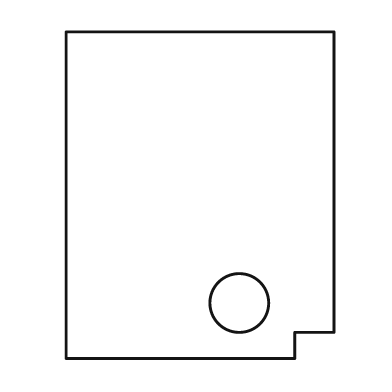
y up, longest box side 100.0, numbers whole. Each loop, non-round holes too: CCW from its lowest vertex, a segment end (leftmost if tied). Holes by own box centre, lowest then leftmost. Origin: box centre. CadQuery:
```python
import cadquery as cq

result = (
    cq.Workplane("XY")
    .moveTo(-41.0, -50.0)
    .lineTo(29.0, -50.0)
    .lineTo(29.0, -42.0)
    .lineTo(41.0, -42.0)
    .lineTo(41.0, 50.0)
    .lineTo(-41.0, 50.0)
    .close()
    .moveTo(12.0, -33.0)
    .circle(9.0)
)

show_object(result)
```